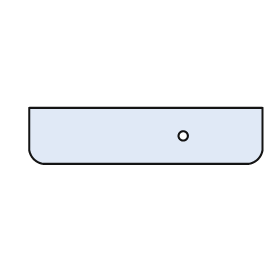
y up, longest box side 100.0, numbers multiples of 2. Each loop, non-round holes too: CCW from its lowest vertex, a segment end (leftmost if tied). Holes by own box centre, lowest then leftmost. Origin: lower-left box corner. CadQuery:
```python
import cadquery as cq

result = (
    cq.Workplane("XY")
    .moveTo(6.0, 0.0)
    .lineTo(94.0, 0.0)
    .threePointArc((98.0, 2.0), (100.0, 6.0))
    .lineTo(100.0, 24.0)
    .lineTo(0.0, 24.0)
    .lineTo(0.0, 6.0)
    .threePointArc((2.0, 2.0), (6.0, 0.0))
    .close()
    .moveTo(66.0, 12.0)
    .circle(2.0)
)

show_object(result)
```